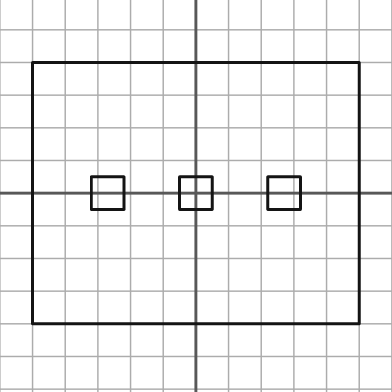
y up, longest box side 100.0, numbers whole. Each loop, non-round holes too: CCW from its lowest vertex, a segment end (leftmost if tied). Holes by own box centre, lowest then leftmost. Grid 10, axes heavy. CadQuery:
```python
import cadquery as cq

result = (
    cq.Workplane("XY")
    .moveTo(-50.0, -40.0)
    .lineTo(50.0, -40.0)
    .lineTo(50.0, 40.0)
    .lineTo(-50.0, 40.0)
    .close()
    .moveTo(-32.0, -5.0)
    .lineTo(-22.0, -5.0)
    .lineTo(-22.0, 5.0)
    .lineTo(-32.0, 5.0)
    .close()
    .moveTo(-5.0, -5.0)
    .lineTo(5.0, -5.0)
    .lineTo(5.0, 5.0)
    .lineTo(-5.0, 5.0)
    .close()
    .moveTo(22.0, -5.0)
    .lineTo(32.0, -5.0)
    .lineTo(32.0, 5.0)
    .lineTo(22.0, 5.0)
    .close()
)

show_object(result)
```